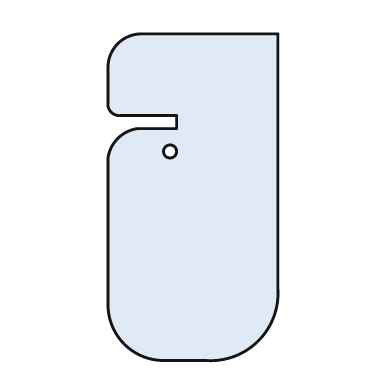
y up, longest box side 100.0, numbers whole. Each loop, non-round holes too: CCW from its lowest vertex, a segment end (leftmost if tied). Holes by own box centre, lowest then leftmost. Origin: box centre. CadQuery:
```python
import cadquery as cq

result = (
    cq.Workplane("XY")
    .moveTo(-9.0, -50.0)
    .lineTo(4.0, -50.0)
    .threePointArc((20.0, -44.0), (26.0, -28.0))
    .lineTo(26.0, 50.0)
    .lineTo(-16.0, 50.0)
    .threePointArc((-23.0, 47.0), (-26.0, 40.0))
    .lineTo(-26.0, 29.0)
    .threePointArc((-25.0, 26.0), (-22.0, 25.0))
    .lineTo(-5.0, 25.0)
    .lineTo(-5.0, 21.0)
    .lineTo(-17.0, 21.0)
    .threePointArc((-23.0, 18.0), (-26.0, 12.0))
    .lineTo(-26.0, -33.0)
    .threePointArc((-21.0, -45.0), (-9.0, -50.0))
    .close()
    .moveTo(-7.0, 14.0)
    .circle(2.0)
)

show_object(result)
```